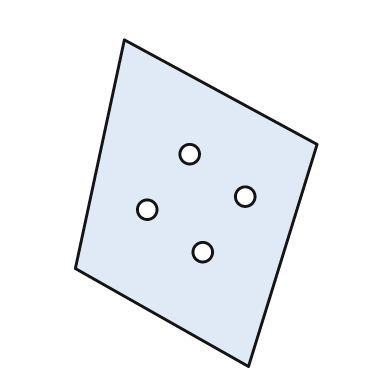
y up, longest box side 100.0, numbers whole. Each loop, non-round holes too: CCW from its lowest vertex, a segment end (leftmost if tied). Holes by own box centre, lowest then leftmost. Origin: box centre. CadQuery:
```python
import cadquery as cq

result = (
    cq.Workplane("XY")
    .moveTo(16.0, -50.0)
    .lineTo(37.0, 18.0)
    .lineTo(-22.0, 50.0)
    .lineTo(-37.0, -20.0)
    .close()
    .moveTo(2.0, -15.0)
    .circle(3.0)
    .moveTo(-15.0, -2.0)
    .circle(3.0)
    .moveTo(15.0, 2.0)
    .circle(3.0)
    .moveTo(-2.0, 15.0)
    .circle(3.0)
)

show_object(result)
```